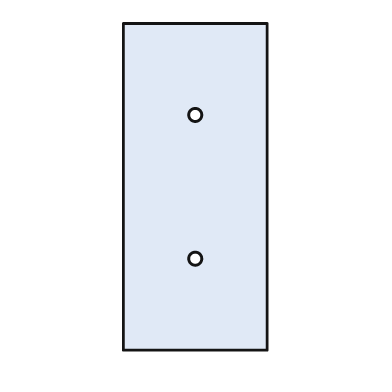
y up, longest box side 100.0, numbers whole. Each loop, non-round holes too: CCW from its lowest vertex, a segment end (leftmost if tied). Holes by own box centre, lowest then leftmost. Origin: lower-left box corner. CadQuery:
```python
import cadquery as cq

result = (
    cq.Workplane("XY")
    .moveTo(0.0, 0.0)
    .lineTo(44.0, 0.0)
    .lineTo(44.0, 100.0)
    .lineTo(0.0, 100.0)
    .close()
    .moveTo(22.0, 28.0)
    .circle(2.0)
    .moveTo(22.0, 72.0)
    .circle(2.0)
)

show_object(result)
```